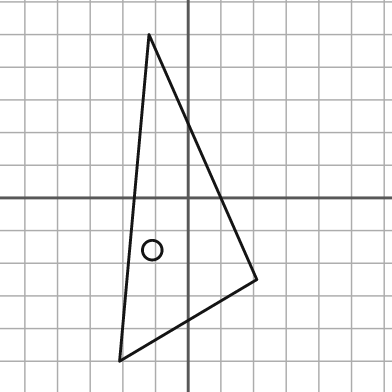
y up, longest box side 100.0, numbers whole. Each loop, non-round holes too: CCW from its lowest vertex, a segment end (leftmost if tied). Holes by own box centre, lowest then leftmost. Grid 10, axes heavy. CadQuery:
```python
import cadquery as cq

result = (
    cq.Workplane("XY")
    .moveTo(-21.0, -50.0)
    .lineTo(21.0, -25.0)
    .lineTo(-12.0, 50.0)
    .close()
    .moveTo(-11.0, -16.0)
    .circle(3.0)
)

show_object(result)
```